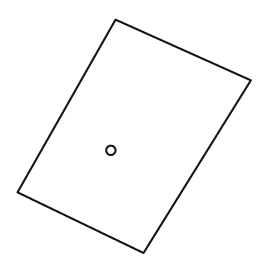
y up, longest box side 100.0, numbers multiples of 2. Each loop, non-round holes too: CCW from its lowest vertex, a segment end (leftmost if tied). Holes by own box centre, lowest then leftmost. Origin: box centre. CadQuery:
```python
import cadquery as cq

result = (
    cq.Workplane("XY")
    .moveTo(4.0, -50.0)
    .lineTo(50.0, 24.0)
    .lineTo(-8.0, 50.0)
    .lineTo(-50.0, -24.0)
    .close()
    .moveTo(-10.0, -6.0)
    .circle(2.0)
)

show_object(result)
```